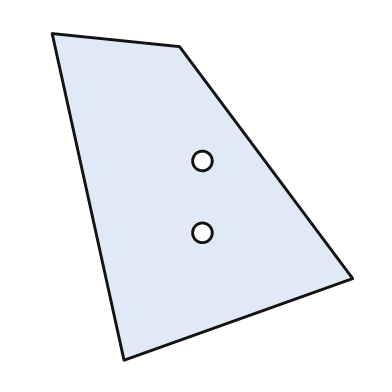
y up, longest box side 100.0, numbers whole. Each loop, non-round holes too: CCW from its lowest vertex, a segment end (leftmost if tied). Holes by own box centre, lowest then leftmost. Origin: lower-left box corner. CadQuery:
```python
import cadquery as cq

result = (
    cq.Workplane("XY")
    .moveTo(22.0, 0.0)
    .lineTo(92.0, 25.0)
    .lineTo(39.0, 96.0)
    .lineTo(0.0, 100.0)
    .close()
    .moveTo(46.0, 39.0)
    .circle(3.0)
    .moveTo(46.0, 61.0)
    .circle(3.0)
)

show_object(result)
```